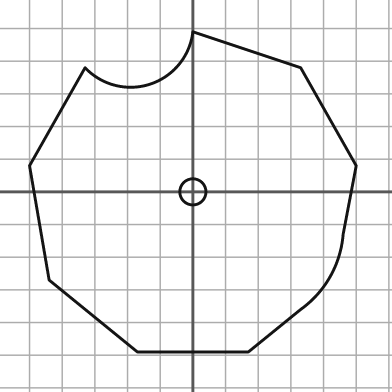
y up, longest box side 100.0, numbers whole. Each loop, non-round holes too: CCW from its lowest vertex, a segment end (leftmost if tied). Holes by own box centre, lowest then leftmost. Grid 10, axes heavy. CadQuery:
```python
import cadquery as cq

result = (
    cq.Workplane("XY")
    .moveTo(-17.0, -49.0)
    .lineTo(17.0, -49.0)
    .lineTo(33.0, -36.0)
    .threePointArc((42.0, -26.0), (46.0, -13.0))
    .lineTo(50.0, 8.0)
    .lineTo(33.0, 38.0)
    .lineTo(0.0, 49.0)
    .threePointArc((-13.0, 33.0), (-33.0, 38.0))
    .lineTo(-50.0, 8.0)
    .lineTo(-44.0, -27.0)
    .close()
    .moveTo(0.0, 0.0)
    .circle(4.0)
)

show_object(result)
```